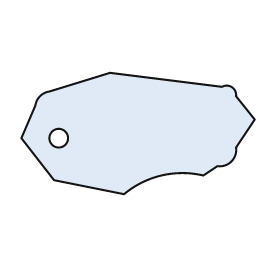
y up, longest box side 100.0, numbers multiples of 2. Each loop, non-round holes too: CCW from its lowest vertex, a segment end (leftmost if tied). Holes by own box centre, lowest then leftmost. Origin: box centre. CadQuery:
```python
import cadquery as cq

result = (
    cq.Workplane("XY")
    .moveTo(-6.0, -26.0)
    .threePointArc((10.0, -18.0), (28.0, -18.0))
    .lineTo(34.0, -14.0)
    .threePointArc((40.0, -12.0), (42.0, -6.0))
    .lineTo(50.0, 6.0)
    .lineTo(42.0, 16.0)
    .threePointArc((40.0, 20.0), (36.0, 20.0))
    .lineTo(-12.0, 26.0)
    .lineTo(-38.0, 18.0)
    .threePointArc((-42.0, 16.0), (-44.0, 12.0))
    .lineTo(-50.0, -2.0)
    .lineTo(-36.0, -20.0)
    .close()
    .moveTo(-34.0, -2.0)
    .circle(4.0)
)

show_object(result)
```